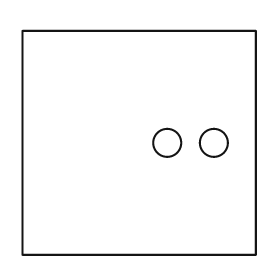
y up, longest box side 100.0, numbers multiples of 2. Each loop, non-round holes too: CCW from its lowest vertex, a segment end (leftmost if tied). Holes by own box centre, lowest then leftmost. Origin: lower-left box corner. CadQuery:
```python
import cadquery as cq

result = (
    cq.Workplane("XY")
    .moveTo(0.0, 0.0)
    .lineTo(100.0, 0.0)
    .lineTo(100.0, 96.0)
    .lineTo(0.0, 96.0)
    .close()
    .moveTo(62.0, 48.0)
    .circle(6.0)
    .moveTo(82.0, 48.0)
    .circle(6.0)
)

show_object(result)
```